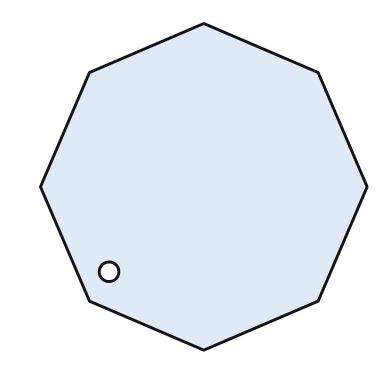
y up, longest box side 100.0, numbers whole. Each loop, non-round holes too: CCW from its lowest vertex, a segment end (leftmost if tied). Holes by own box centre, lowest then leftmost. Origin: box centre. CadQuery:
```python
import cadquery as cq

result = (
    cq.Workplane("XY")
    .moveTo(0.0, -50.0)
    .lineTo(35.0, -35.0)
    .lineTo(50.0, 0.0)
    .lineTo(35.0, 35.0)
    .lineTo(0.0, 50.0)
    .lineTo(-35.0, 35.0)
    .lineTo(-50.0, 0.0)
    .lineTo(-35.0, -35.0)
    .close()
    .moveTo(-29.0, -26.0)
    .circle(3.0)
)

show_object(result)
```